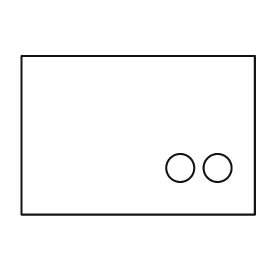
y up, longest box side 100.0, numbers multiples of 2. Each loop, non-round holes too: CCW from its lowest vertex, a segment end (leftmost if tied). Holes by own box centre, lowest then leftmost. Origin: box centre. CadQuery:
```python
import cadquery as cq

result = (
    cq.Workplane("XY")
    .moveTo(-50.0, -34.0)
    .lineTo(50.0, -34.0)
    .lineTo(50.0, 34.0)
    .lineTo(-50.0, 34.0)
    .close()
    .moveTo(18.0, -14.0)
    .circle(6.0)
    .moveTo(34.0, -14.0)
    .circle(6.0)
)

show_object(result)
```